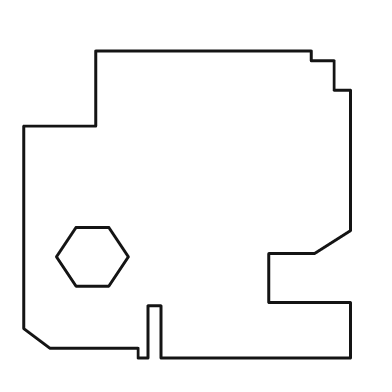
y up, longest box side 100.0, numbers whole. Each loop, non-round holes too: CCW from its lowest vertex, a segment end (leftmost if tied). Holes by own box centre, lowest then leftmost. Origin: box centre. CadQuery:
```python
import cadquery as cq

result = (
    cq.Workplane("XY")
    .moveTo(-15.0, -47.0)
    .lineTo(-12.0, -47.0)
    .lineTo(-12.0, -31.0)
    .lineTo(-8.0, -31.0)
    .lineTo(-8.0, -47.0)
    .lineTo(50.0, -47.0)
    .lineTo(50.0, -30.0)
    .lineTo(25.0, -30.0)
    .lineTo(25.0, -15.0)
    .lineTo(39.0, -15.0)
    .lineTo(50.0, -8.0)
    .lineTo(50.0, 35.0)
    .lineTo(45.0, 35.0)
    .lineTo(45.0, 44.0)
    .lineTo(38.0, 44.0)
    .lineTo(38.0, 47.0)
    .lineTo(-28.0, 47.0)
    .lineTo(-28.0, 24.0)
    .lineTo(-50.0, 24.0)
    .lineTo(-50.0, -38.0)
    .lineTo(-42.0, -44.0)
    .lineTo(-15.0, -44.0)
    .close()
    .moveTo(-34.0, -25.0)
    .lineTo(-24.0, -25.0)
    .lineTo(-18.0, -16.0)
    .lineTo(-24.0, -7.0)
    .lineTo(-34.0, -7.0)
    .lineTo(-40.0, -16.0)
    .close()
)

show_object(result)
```